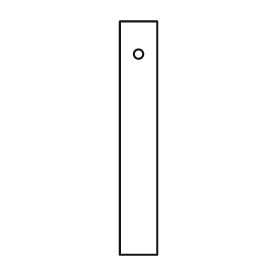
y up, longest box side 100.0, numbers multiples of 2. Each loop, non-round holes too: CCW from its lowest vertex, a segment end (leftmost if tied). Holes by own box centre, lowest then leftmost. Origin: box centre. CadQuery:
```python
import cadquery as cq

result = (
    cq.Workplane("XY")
    .moveTo(-8.0, -50.0)
    .lineTo(8.0, -50.0)
    .lineTo(8.0, 50.0)
    .lineTo(-8.0, 50.0)
    .close()
    .moveTo(0.0, 36.0)
    .circle(2.0)
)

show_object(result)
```